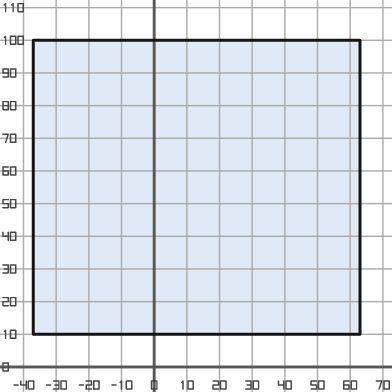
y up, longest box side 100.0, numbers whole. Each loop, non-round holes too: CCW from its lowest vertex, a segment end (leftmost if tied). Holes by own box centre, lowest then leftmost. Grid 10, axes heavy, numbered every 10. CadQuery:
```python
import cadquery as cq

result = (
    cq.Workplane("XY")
    .moveTo(-37.0, 10.0)
    .lineTo(63.0, 10.0)
    .lineTo(63.0, 100.0)
    .lineTo(-37.0, 100.0)
    .close()
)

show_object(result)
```